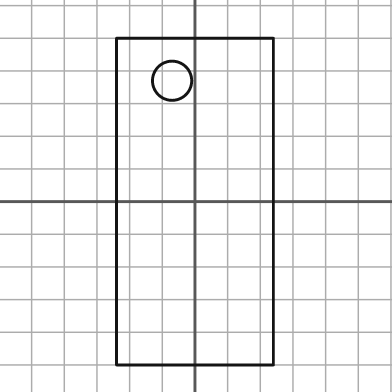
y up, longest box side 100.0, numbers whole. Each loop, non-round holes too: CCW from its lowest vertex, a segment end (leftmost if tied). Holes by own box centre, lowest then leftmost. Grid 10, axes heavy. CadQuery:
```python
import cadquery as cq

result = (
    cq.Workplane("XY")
    .moveTo(-24.0, -50.0)
    .lineTo(24.0, -50.0)
    .lineTo(24.0, 50.0)
    .lineTo(-24.0, 50.0)
    .close()
    .moveTo(-7.0, 37.0)
    .circle(6.0)
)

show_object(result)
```